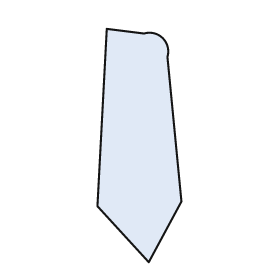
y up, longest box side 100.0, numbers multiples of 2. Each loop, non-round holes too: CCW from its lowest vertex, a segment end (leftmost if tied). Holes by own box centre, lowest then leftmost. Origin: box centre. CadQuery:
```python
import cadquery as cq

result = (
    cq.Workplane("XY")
    .moveTo(4.0, -50.0)
    .lineTo(18.0, -24.0)
    .lineTo(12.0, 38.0)
    .threePointArc((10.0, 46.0), (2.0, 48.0))
    .lineTo(-14.0, 50.0)
    .lineTo(-18.0, -26.0)
    .close()
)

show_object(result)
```